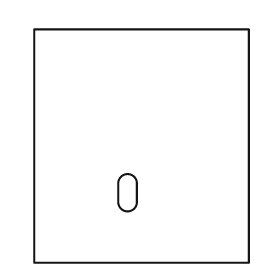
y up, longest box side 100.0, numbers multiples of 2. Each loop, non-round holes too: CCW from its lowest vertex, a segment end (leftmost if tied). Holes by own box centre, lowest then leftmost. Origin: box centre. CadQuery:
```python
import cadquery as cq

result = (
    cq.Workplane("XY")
    .moveTo(-46.0, -50.0)
    .lineTo(46.0, -50.0)
    .lineTo(46.0, 50.0)
    .lineTo(-46.0, 50.0)
    .close()
    .moveTo(-10.0, -24.0)
    .threePointArc((-6.0, -28.0), (-2.0, -24.0))
    .lineTo(-2.0, -16.0)
    .threePointArc((-6.0, -12.0), (-10.0, -16.0))
    .close()
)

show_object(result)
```